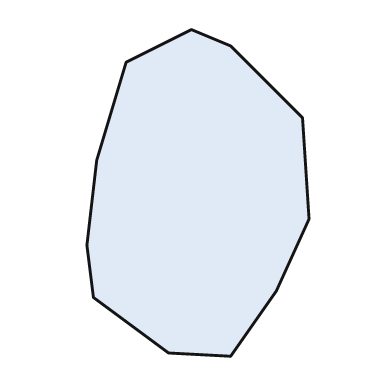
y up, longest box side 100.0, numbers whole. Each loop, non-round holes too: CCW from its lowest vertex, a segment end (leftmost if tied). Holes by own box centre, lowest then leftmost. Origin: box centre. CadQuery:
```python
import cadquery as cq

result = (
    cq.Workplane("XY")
    .moveTo(10.0, -50.0)
    .lineTo(24.0, -30.0)
    .lineTo(34.0, -8.0)
    .lineTo(32.0, 23.0)
    .lineTo(10.0, 45.0)
    .lineTo(-2.0, 50.0)
    .lineTo(-22.0, 40.0)
    .lineTo(-31.0, 10.0)
    .lineTo(-34.0, -16.0)
    .lineTo(-32.0, -32.0)
    .lineTo(-9.0, -49.0)
    .close()
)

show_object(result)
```